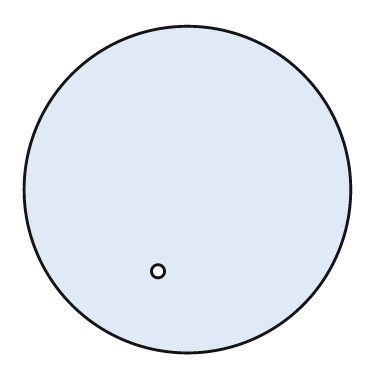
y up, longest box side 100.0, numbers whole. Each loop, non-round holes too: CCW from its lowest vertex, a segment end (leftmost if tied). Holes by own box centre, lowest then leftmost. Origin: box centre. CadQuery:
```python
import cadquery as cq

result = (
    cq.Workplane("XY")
    .moveTo(0.0, 0.0)
    .circle(50.0)
    .moveTo(-9.0, -25.0)
    .circle(2.0)
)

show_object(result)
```